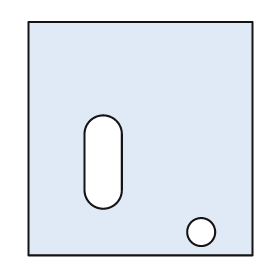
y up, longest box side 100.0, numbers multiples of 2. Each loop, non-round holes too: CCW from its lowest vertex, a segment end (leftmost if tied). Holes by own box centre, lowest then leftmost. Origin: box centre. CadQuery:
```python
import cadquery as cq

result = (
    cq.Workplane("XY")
    .moveTo(-48.0, -50.0)
    .lineTo(48.0, -50.0)
    .lineTo(48.0, 50.0)
    .lineTo(-48.0, 50.0)
    .close()
    .moveTo(26.0, -40.0)
    .circle(6.0)
    .moveTo(-24.0, -22.0)
    .threePointArc((-16.0, -30.0), (-8.0, -22.0))
    .lineTo(-8.0, 2.0)
    .threePointArc((-16.0, 10.0), (-24.0, 2.0))
    .close()
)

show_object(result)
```